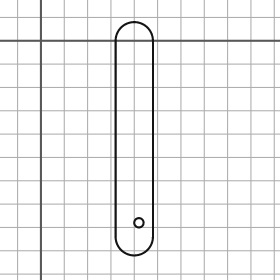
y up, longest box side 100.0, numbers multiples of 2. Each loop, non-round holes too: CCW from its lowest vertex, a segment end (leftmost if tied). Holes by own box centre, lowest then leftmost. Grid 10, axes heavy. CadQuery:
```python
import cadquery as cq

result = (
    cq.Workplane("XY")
    .moveTo(32.0, -84.0)
    .threePointArc((40.0, -92.0), (48.0, -84.0))
    .lineTo(48.0, 0.0)
    .threePointArc((40.0, 8.0), (32.0, 0.0))
    .close()
    .moveTo(42.0, -78.0)
    .circle(2.0)
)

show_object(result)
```